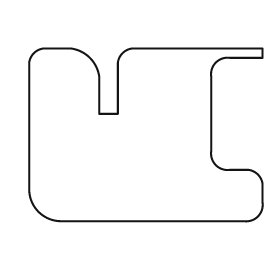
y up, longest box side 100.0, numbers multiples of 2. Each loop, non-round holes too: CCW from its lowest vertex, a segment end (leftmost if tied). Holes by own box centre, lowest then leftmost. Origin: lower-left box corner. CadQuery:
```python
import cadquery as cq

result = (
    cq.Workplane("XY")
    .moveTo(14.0, 0.0)
    .lineTo(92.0, 0.0)
    .threePointArc((98.0, 2.0), (100.0, 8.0))
    .lineTo(100.0, 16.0)
    .threePointArc((98.0, 20.0), (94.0, 22.0))
    .lineTo(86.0, 22.0)
    .threePointArc((80.0, 24.0), (78.0, 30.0))
    .lineTo(78.0, 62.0)
    .threePointArc((80.0, 68.0), (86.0, 70.0))
    .lineTo(100.0, 70.0)
    .lineTo(100.0, 74.0)
    .lineTo(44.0, 74.0)
    .threePointArc((40.0, 72.0), (38.0, 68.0))
    .lineTo(38.0, 46.0)
    .lineTo(30.0, 46.0)
    .lineTo(30.0, 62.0)
    .threePointArc((26.0, 70.0), (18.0, 74.0))
    .lineTo(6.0, 74.0)
    .threePointArc((2.0, 72.0), (0.0, 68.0))
    .lineTo(0.0, 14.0)
    .threePointArc((4.0, 4.0), (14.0, 0.0))
    .close()
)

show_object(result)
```